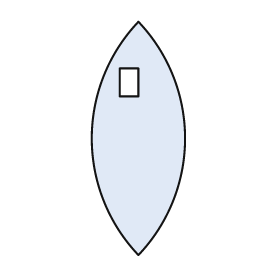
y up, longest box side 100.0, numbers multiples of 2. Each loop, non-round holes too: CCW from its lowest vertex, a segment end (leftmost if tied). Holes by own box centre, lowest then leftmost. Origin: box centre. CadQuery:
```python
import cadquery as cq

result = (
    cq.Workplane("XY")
    .moveTo(0.0, -50.0)
    .threePointArc((20.0, 0.0), (0.0, 50.0))
    .threePointArc((-20.0, 0.0), (0.0, -50.0))
    .close()
    .moveTo(-8.0, 18.0)
    .lineTo(0.0, 18.0)
    .lineTo(0.0, 30.0)
    .lineTo(-8.0, 30.0)
    .close()
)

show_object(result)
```